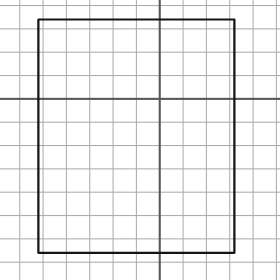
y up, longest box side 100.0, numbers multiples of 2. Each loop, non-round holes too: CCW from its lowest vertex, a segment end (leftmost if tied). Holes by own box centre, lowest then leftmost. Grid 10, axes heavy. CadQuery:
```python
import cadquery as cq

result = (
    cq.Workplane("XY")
    .moveTo(-52.0, -66.0)
    .lineTo(32.0, -66.0)
    .lineTo(32.0, 34.0)
    .lineTo(-52.0, 34.0)
    .close()
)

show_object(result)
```